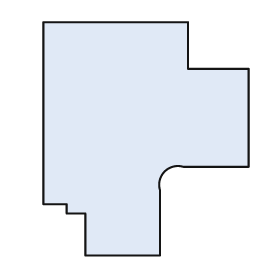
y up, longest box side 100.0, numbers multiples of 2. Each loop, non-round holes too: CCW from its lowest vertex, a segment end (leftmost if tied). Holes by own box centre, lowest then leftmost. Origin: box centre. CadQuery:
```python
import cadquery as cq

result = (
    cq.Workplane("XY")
    .moveTo(-26.0, -50.0)
    .lineTo(6.0, -50.0)
    .lineTo(6.0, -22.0)
    .threePointArc((8.0, -14.0), (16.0, -12.0))
    .lineTo(44.0, -12.0)
    .lineTo(44.0, 30.0)
    .lineTo(18.0, 30.0)
    .lineTo(18.0, 50.0)
    .lineTo(-44.0, 50.0)
    .lineTo(-44.0, -28.0)
    .lineTo(-34.0, -28.0)
    .lineTo(-34.0, -32.0)
    .lineTo(-26.0, -32.0)
    .close()
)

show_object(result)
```